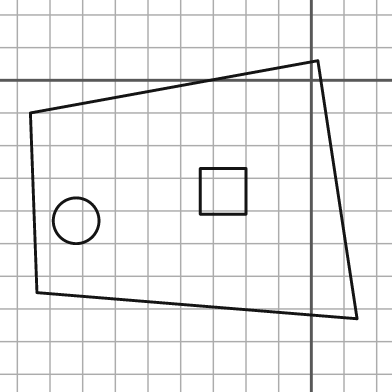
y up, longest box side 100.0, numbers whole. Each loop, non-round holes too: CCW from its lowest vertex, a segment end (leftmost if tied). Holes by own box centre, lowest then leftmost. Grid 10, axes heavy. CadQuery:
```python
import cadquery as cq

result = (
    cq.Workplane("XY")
    .moveTo(14.0, -73.0)
    .lineTo(2.0, 6.0)
    .lineTo(-86.0, -10.0)
    .lineTo(-84.0, -65.0)
    .close()
    .moveTo(-72.0, -43.0)
    .circle(7.0)
    .moveTo(-34.0, -41.0)
    .lineTo(-20.0, -41.0)
    .lineTo(-20.0, -27.0)
    .lineTo(-34.0, -27.0)
    .close()
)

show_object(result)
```